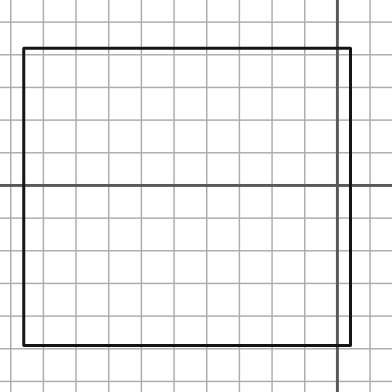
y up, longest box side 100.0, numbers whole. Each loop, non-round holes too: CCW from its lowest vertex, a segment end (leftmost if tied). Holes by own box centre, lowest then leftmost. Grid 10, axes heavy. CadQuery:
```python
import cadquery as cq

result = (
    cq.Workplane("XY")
    .moveTo(-96.0, -49.0)
    .lineTo(4.0, -49.0)
    .lineTo(4.0, 42.0)
    .lineTo(-96.0, 42.0)
    .close()
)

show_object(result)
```